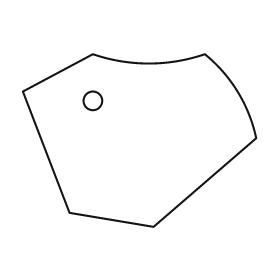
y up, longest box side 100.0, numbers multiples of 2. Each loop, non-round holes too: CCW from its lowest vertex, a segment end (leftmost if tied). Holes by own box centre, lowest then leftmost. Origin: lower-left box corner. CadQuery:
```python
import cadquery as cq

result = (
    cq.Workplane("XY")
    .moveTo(56.0, 0.0)
    .lineTo(100.0, 38.0)
    .threePointArc((92.0, 58.0), (78.0, 74.0))
    .threePointArc((54.0, 70.0), (30.0, 74.0))
    .lineTo(0.0, 58.0)
    .lineTo(20.0, 6.0)
    .close()
    .moveTo(30.0, 54.0)
    .circle(4.0)
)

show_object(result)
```